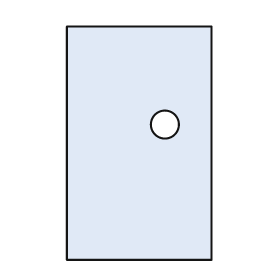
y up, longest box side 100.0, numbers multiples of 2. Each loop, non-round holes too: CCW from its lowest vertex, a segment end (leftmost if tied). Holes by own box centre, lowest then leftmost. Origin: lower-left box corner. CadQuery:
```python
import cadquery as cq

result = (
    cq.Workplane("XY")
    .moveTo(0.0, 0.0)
    .lineTo(62.0, 0.0)
    .lineTo(62.0, 100.0)
    .lineTo(0.0, 100.0)
    .close()
    .moveTo(42.0, 58.0)
    .circle(6.0)
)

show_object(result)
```